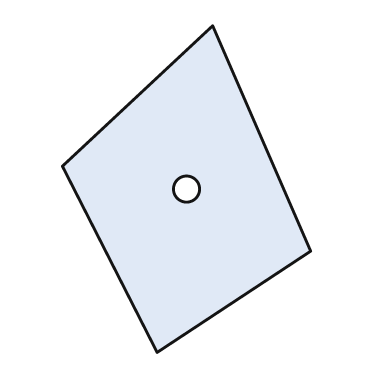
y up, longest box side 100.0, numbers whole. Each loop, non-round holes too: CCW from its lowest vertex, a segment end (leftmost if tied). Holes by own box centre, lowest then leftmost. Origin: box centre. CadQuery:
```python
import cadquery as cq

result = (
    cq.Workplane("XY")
    .moveTo(-9.0, -50.0)
    .lineTo(38.0, -19.0)
    .lineTo(8.0, 50.0)
    .lineTo(-38.0, 7.0)
    .close()
    .moveTo(0.0, 0.0)
    .circle(4.0)
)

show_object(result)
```